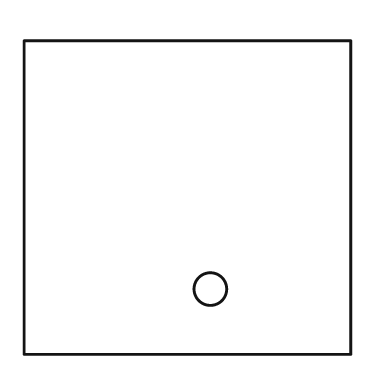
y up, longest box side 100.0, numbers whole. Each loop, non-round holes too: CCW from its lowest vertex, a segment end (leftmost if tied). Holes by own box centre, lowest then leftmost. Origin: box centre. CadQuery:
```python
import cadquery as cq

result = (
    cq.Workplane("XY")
    .moveTo(-50.0, -48.0)
    .lineTo(50.0, -48.0)
    .lineTo(50.0, 48.0)
    .lineTo(-50.0, 48.0)
    .close()
    .moveTo(7.0, -28.0)
    .circle(5.0)
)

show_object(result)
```